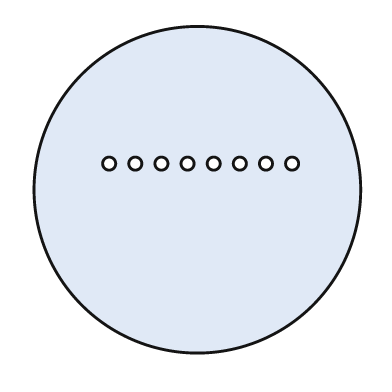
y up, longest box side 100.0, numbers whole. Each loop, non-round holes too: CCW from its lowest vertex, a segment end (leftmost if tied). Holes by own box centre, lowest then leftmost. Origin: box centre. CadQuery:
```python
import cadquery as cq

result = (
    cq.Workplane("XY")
    .moveTo(0.0, 0.0)
    .circle(50.0)
    .moveTo(-27.0, 8.0)
    .circle(2.0)
    .moveTo(-19.0, 8.0)
    .circle(2.0)
    .moveTo(-11.0, 8.0)
    .circle(2.0)
    .moveTo(-3.0, 8.0)
    .circle(2.0)
    .moveTo(5.0, 8.0)
    .circle(2.0)
    .moveTo(13.0, 8.0)
    .circle(2.0)
    .moveTo(21.0, 8.0)
    .circle(2.0)
    .moveTo(29.0, 8.0)
    .circle(2.0)
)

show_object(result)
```